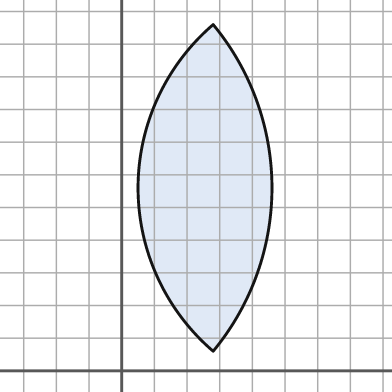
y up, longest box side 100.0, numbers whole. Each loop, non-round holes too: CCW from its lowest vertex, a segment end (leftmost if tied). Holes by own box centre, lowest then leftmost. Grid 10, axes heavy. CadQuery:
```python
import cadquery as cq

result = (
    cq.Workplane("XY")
    .moveTo(28.0, 6.0)
    .threePointArc((46.0, 56.0), (28.0, 106.0))
    .threePointArc((5.0, 56.0), (28.0, 6.0))
    .close()
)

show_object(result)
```